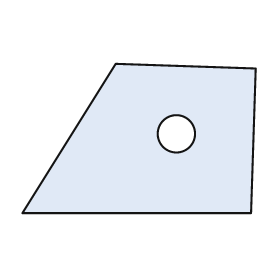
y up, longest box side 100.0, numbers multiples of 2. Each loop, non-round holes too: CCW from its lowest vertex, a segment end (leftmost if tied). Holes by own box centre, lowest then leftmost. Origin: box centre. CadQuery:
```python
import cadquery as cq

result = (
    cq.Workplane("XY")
    .moveTo(-50.0, -32.0)
    .lineTo(48.0, -32.0)
    .lineTo(50.0, 30.0)
    .lineTo(-10.0, 32.0)
    .close()
    .moveTo(16.0, 2.0)
    .circle(8.0)
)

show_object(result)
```